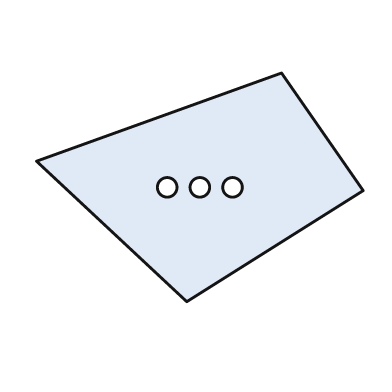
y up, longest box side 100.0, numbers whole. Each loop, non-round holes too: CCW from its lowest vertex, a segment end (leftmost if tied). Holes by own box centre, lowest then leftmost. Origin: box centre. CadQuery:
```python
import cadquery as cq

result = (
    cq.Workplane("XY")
    .moveTo(-4.0, -35.0)
    .lineTo(50.0, -1.0)
    .lineTo(25.0, 35.0)
    .lineTo(-50.0, 8.0)
    .close()
    .moveTo(-10.0, 0.0)
    .circle(3.0)
    .moveTo(0.0, 0.0)
    .circle(3.0)
    .moveTo(10.0, 0.0)
    .circle(3.0)
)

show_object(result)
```